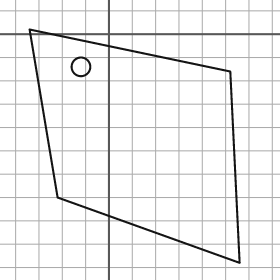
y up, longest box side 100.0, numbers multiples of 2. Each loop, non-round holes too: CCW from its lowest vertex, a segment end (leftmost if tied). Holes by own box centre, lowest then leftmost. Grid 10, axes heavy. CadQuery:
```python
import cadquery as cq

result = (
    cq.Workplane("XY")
    .moveTo(56.0, -98.0)
    .lineTo(52.0, -16.0)
    .lineTo(-34.0, 2.0)
    .lineTo(-22.0, -70.0)
    .close()
    .moveTo(-12.0, -14.0)
    .circle(4.0)
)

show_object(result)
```